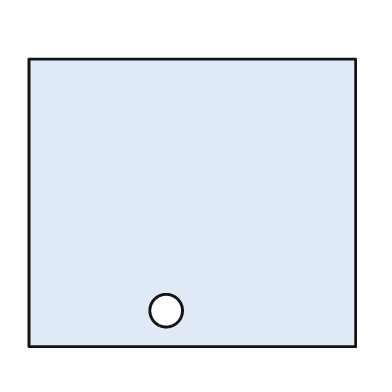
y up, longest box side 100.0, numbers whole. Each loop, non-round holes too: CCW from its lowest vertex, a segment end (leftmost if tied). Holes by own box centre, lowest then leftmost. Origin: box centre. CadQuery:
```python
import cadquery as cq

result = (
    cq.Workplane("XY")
    .moveTo(-50.0, -44.0)
    .lineTo(50.0, -44.0)
    .lineTo(50.0, 44.0)
    .lineTo(-50.0, 44.0)
    .close()
    .moveTo(-8.0, -33.0)
    .circle(5.0)
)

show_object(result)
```